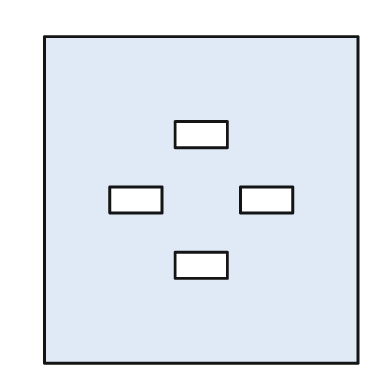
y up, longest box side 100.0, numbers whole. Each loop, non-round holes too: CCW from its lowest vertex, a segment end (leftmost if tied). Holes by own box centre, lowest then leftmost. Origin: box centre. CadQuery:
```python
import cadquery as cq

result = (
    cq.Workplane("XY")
    .moveTo(-48.0, -50.0)
    .lineTo(48.0, -50.0)
    .lineTo(48.0, 50.0)
    .lineTo(-48.0, 50.0)
    .close()
    .moveTo(-8.0, -24.0)
    .lineTo(8.0, -24.0)
    .lineTo(8.0, -16.0)
    .lineTo(-8.0, -16.0)
    .close()
    .moveTo(-28.0, -4.0)
    .lineTo(-12.0, -4.0)
    .lineTo(-12.0, 4.0)
    .lineTo(-28.0, 4.0)
    .close()
    .moveTo(12.0, -4.0)
    .lineTo(28.0, -4.0)
    .lineTo(28.0, 4.0)
    .lineTo(12.0, 4.0)
    .close()
    .moveTo(-8.0, 16.0)
    .lineTo(8.0, 16.0)
    .lineTo(8.0, 24.0)
    .lineTo(-8.0, 24.0)
    .close()
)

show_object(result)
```